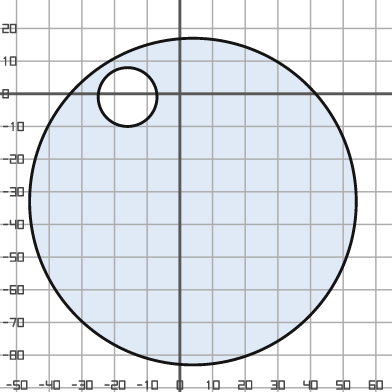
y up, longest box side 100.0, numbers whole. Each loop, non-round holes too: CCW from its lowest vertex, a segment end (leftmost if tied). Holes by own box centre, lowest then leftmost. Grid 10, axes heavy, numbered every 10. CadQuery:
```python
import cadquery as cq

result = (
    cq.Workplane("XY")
    .moveTo(4.0, -33.0)
    .circle(50.0)
    .moveTo(-16.0, -1.0)
    .circle(9.0)
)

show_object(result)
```